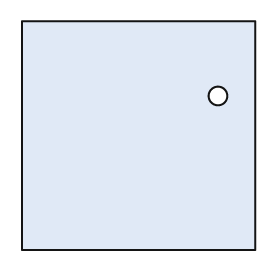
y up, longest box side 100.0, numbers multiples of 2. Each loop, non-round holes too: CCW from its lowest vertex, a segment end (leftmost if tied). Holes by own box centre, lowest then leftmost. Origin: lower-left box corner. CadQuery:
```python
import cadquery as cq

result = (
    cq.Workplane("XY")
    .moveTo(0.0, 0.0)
    .lineTo(100.0, 0.0)
    .lineTo(100.0, 98.0)
    .lineTo(0.0, 98.0)
    .close()
    .moveTo(84.0, 66.0)
    .circle(4.0)
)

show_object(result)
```